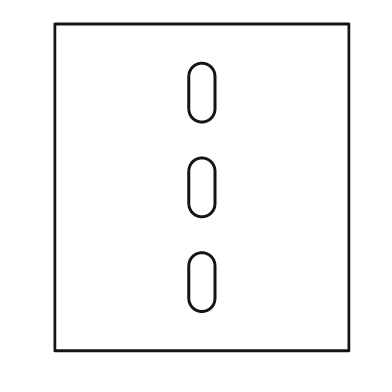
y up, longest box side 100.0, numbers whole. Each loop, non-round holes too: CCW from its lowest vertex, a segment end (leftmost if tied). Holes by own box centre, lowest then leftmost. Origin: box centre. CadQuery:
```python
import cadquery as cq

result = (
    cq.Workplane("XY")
    .moveTo(-45.0, -50.0)
    .lineTo(45.0, -50.0)
    .lineTo(45.0, 50.0)
    .lineTo(-45.0, 50.0)
    .close()
    .moveTo(-4.0, -34.0)
    .threePointArc((0.0, -38.0), (4.0, -34.0))
    .lineTo(4.0, -24.0)
    .threePointArc((0.0, -20.0), (-4.0, -24.0))
    .close()
    .moveTo(-4.0, -5.0)
    .threePointArc((0.0, -9.0), (4.0, -5.0))
    .lineTo(4.0, 5.0)
    .threePointArc((0.0, 9.0), (-4.0, 5.0))
    .close()
    .moveTo(-4.0, 24.0)
    .threePointArc((0.0, 20.0), (4.0, 24.0))
    .lineTo(4.0, 34.0)
    .threePointArc((0.0, 38.0), (-4.0, 34.0))
    .close()
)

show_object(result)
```